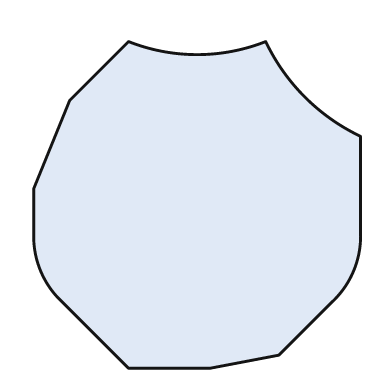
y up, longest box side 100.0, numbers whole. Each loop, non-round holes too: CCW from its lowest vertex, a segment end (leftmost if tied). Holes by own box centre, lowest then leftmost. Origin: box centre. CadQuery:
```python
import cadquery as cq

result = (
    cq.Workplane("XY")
    .moveTo(-21.0, -50.0)
    .lineTo(4.0, -50.0)
    .lineTo(25.0, -46.0)
    .lineTo(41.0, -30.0)
    .threePointArc((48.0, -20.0), (50.0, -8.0))
    .lineTo(50.0, 21.0)
    .threePointArc((33.0, 33.0), (21.0, 50.0))
    .threePointArc((0.0, 46.0), (-21.0, 50.0))
    .lineTo(-39.0, 32.0)
    .lineTo(-50.0, 5.0)
    .lineTo(-50.0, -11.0)
    .threePointArc((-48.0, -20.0), (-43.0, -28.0))
    .close()
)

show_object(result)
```